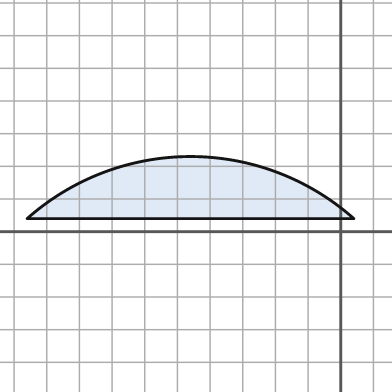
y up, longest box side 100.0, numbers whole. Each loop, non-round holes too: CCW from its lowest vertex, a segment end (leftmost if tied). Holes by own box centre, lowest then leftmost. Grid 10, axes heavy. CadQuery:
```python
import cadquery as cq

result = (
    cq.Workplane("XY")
    .moveTo(-96.0, 4.0)
    .lineTo(4.0, 4.0)
    .threePointArc((-46.0, 23.0), (-96.0, 4.0))
    .close()
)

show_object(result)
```